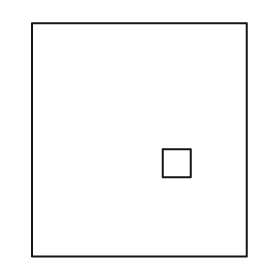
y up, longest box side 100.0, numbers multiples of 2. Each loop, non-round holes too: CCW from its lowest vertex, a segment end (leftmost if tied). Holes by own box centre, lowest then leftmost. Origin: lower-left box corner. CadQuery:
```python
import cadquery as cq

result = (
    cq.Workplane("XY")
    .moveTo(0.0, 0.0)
    .lineTo(92.0, 0.0)
    .lineTo(92.0, 100.0)
    .lineTo(0.0, 100.0)
    .close()
    .moveTo(56.0, 34.0)
    .lineTo(68.0, 34.0)
    .lineTo(68.0, 46.0)
    .lineTo(56.0, 46.0)
    .close()
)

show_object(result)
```